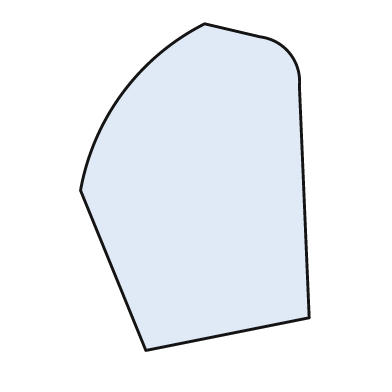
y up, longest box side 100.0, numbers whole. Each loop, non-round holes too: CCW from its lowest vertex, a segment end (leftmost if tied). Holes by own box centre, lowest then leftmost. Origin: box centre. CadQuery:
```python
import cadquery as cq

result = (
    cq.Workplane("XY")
    .moveTo(-15.0, -50.0)
    .lineTo(35.0, -40.0)
    .lineTo(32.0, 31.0)
    .threePointArc((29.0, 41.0), (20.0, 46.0))
    .lineTo(3.0, 50.0)
    .threePointArc((-22.0, 29.0), (-35.0, -1.0))
    .close()
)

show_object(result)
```